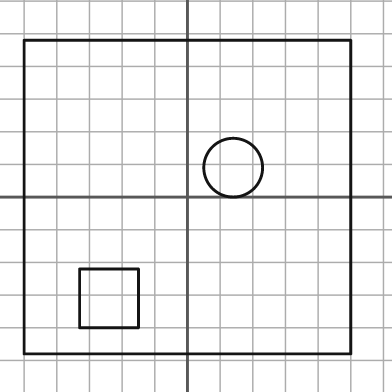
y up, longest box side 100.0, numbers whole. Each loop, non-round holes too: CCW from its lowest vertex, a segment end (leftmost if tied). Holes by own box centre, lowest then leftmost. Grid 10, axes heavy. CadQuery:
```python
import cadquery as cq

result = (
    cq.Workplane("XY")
    .moveTo(-50.0, -48.0)
    .lineTo(50.0, -48.0)
    .lineTo(50.0, 48.0)
    .lineTo(-50.0, 48.0)
    .close()
    .moveTo(-33.0, -40.0)
    .lineTo(-15.0, -40.0)
    .lineTo(-15.0, -22.0)
    .lineTo(-33.0, -22.0)
    .close()
    .moveTo(14.0, 9.0)
    .circle(9.0)
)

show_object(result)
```